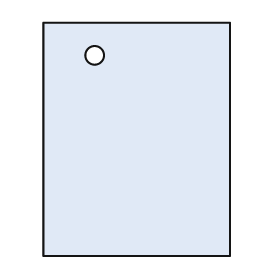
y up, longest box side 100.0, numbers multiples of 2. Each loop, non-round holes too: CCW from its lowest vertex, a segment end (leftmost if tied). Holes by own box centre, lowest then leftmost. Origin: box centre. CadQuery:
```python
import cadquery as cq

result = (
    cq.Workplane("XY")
    .moveTo(-40.0, -50.0)
    .lineTo(40.0, -50.0)
    .lineTo(40.0, 50.0)
    .lineTo(-40.0, 50.0)
    .close()
    .moveTo(-18.0, 36.0)
    .circle(4.0)
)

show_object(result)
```